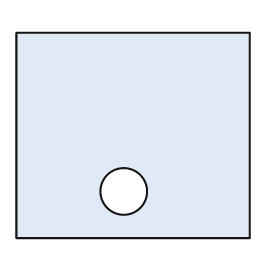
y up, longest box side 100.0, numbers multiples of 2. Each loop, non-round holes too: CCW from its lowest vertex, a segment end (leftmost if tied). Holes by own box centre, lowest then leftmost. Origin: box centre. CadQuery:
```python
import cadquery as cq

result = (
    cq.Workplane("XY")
    .moveTo(-50.0, -44.0)
    .lineTo(50.0, -44.0)
    .lineTo(50.0, 44.0)
    .lineTo(-50.0, 44.0)
    .close()
    .moveTo(-4.0, -24.0)
    .circle(10.0)
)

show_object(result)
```